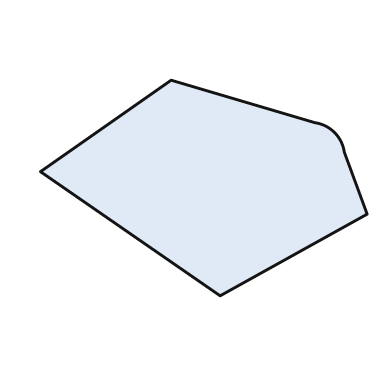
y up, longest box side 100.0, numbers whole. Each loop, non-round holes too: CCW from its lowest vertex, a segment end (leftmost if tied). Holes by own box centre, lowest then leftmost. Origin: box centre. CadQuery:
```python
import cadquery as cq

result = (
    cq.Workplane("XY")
    .moveTo(5.0, -33.0)
    .lineTo(50.0, -8.0)
    .lineTo(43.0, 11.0)
    .threePointArc((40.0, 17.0), (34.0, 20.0))
    .lineTo(-10.0, 33.0)
    .lineTo(-50.0, 5.0)
    .close()
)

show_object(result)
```